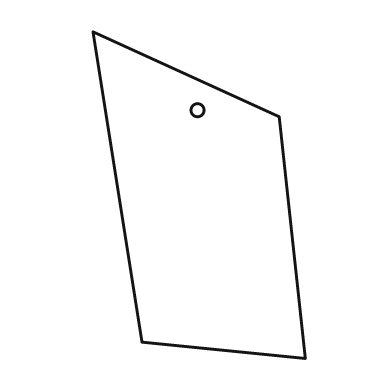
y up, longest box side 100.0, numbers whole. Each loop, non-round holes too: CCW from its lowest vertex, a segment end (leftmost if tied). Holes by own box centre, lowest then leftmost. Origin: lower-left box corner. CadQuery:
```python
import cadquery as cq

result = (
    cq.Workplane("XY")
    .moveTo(65.0, 0.0)
    .lineTo(57.0, 74.0)
    .lineTo(0.0, 100.0)
    .lineTo(15.0, 5.0)
    .close()
    .moveTo(32.0, 76.0)
    .circle(2.0)
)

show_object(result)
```